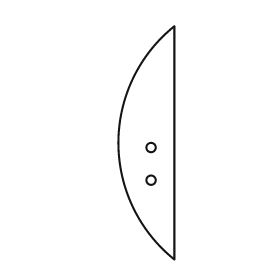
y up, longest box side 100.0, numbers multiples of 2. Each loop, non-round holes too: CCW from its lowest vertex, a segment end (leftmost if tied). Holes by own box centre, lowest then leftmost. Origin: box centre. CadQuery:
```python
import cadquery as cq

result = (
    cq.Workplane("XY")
    .moveTo(12.0, -50.0)
    .lineTo(12.0, 50.0)
    .threePointArc((-12.0, 0.0), (12.0, -50.0))
    .close()
    .moveTo(2.0, -16.0)
    .circle(2.0)
    .moveTo(2.0, -2.0)
    .circle(2.0)
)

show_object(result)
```